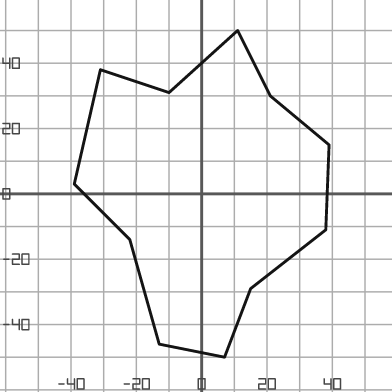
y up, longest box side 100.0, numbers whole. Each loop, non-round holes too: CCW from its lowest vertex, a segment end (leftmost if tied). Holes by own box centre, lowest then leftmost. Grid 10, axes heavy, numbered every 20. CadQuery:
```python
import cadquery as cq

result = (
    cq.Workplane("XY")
    .moveTo(7.0, -50.0)
    .lineTo(15.0, -29.0)
    .lineTo(38.0, -11.0)
    .lineTo(39.0, 15.0)
    .lineTo(21.0, 30.0)
    .lineTo(11.0, 50.0)
    .lineTo(-10.0, 31.0)
    .lineTo(-31.0, 38.0)
    .lineTo(-39.0, 3.0)
    .lineTo(-22.0, -14.0)
    .lineTo(-13.0, -46.0)
    .close()
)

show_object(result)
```